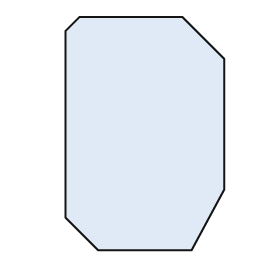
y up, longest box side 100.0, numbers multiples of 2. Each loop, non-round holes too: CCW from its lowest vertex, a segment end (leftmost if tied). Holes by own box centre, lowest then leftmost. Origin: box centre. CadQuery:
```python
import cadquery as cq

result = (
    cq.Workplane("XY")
    .moveTo(-20.0, -50.0)
    .lineTo(20.0, -50.0)
    .lineTo(34.0, -24.0)
    .lineTo(34.0, 32.0)
    .lineTo(16.0, 50.0)
    .lineTo(-28.0, 50.0)
    .lineTo(-34.0, 44.0)
    .lineTo(-34.0, -36.0)
    .close()
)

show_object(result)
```